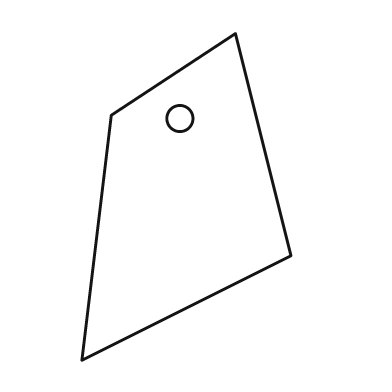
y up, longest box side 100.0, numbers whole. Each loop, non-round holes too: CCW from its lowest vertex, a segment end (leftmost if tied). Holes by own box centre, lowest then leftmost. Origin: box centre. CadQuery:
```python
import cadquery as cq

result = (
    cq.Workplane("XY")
    .moveTo(-32.0, -50.0)
    .lineTo(32.0, -18.0)
    .lineTo(15.0, 50.0)
    .lineTo(-23.0, 25.0)
    .close()
    .moveTo(-2.0, 24.0)
    .circle(4.0)
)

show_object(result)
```